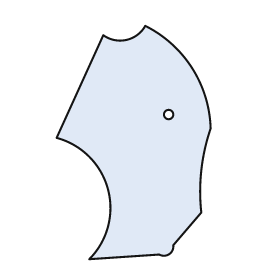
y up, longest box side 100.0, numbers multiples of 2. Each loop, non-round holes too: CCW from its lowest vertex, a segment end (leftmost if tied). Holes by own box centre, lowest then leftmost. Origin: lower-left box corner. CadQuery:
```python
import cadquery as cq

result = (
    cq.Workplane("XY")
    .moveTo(14.0, 0.0)
    .lineTo(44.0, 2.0)
    .threePointArc((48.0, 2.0), (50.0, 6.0))
    .lineTo(62.0, 20.0)
    .threePointArc((62.0, 38.0), (66.0, 56.0))
    .threePointArc((58.0, 82.0), (38.0, 100.0))
    .threePointArc((30.0, 94.0), (20.0, 96.0))
    .lineTo(0.0, 52.0)
    .threePointArc((22.0, 30.0), (14.0, 0.0))
    .close()
    .moveTo(48.0, 62.0)
    .circle(2.0)
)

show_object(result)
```